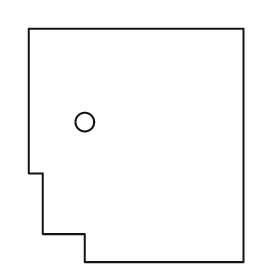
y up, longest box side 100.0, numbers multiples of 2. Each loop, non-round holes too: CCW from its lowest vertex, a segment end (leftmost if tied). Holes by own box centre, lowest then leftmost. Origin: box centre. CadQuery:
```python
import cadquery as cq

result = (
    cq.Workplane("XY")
    .moveTo(-22.0, -50.0)
    .lineTo(46.0, -50.0)
    .lineTo(46.0, 50.0)
    .lineTo(-46.0, 50.0)
    .lineTo(-46.0, -12.0)
    .lineTo(-40.0, -12.0)
    .lineTo(-40.0, -38.0)
    .lineTo(-22.0, -38.0)
    .close()
    .moveTo(-22.0, 10.0)
    .circle(4.0)
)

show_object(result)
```